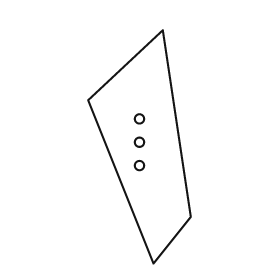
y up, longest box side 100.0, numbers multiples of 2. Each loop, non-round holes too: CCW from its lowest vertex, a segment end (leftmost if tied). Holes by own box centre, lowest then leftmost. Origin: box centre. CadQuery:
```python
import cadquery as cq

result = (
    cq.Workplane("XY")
    .moveTo(6.0, -50.0)
    .lineTo(22.0, -30.0)
    .lineTo(10.0, 50.0)
    .lineTo(-22.0, 20.0)
    .close()
    .moveTo(0.0, -8.0)
    .circle(2.0)
    .moveTo(0.0, 2.0)
    .circle(2.0)
    .moveTo(0.0, 12.0)
    .circle(2.0)
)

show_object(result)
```